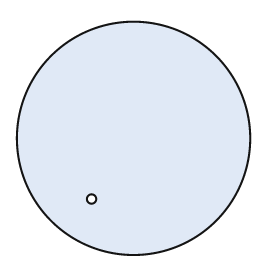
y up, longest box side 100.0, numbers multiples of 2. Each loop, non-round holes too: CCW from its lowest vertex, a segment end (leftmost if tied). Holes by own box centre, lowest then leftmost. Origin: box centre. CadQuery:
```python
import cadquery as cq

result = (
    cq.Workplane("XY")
    .moveTo(0.0, 0.0)
    .circle(50.0)
    .moveTo(-18.0, -26.0)
    .circle(2.0)
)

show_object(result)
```